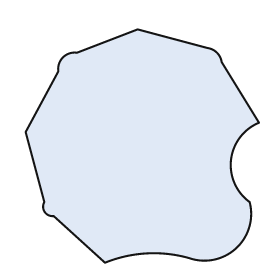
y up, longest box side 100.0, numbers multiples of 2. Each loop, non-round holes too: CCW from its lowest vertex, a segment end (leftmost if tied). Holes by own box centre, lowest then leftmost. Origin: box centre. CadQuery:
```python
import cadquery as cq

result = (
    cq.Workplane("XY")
    .moveTo(-16.0, -50.0)
    .threePointArc((2.0, -46.0), (20.0, -48.0))
    .threePointArc((40.0, -44.0), (46.0, -24.0))
    .threePointArc((38.0, -6.0), (50.0, 10.0))
    .lineTo(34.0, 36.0)
    .threePointArc((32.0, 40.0), (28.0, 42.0))
    .lineTo(-2.0, 50.0)
    .lineTo(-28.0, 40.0)
    .threePointArc((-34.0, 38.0), (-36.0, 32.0))
    .lineTo(-50.0, 6.0)
    .lineTo(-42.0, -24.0)
    .threePointArc((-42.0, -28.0), (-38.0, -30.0))
    .close()
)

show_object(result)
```